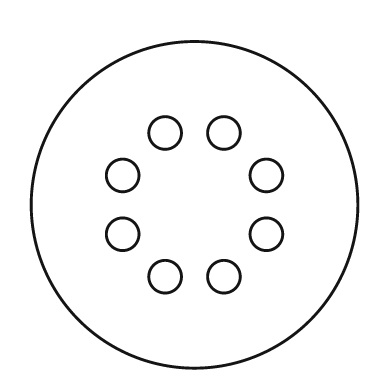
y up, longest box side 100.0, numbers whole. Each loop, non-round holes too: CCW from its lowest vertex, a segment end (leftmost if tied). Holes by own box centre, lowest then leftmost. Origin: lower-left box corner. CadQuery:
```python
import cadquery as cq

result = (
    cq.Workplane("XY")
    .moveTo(50.0, 50.0)
    .circle(50.0)
    .moveTo(41.0, 28.0)
    .circle(5.0)
    .moveTo(59.0, 28.0)
    .circle(5.0)
    .moveTo(28.0, 41.0)
    .circle(5.0)
    .moveTo(72.0, 41.0)
    .circle(5.0)
    .moveTo(28.0, 59.0)
    .circle(5.0)
    .moveTo(72.0, 59.0)
    .circle(5.0)
    .moveTo(41.0, 72.0)
    .circle(5.0)
    .moveTo(59.0, 72.0)
    .circle(5.0)
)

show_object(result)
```